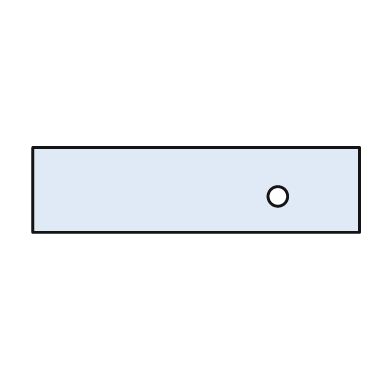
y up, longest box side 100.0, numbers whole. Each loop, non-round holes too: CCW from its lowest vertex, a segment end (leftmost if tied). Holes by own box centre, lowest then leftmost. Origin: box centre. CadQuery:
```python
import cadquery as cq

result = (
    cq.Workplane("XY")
    .moveTo(-50.0, -13.0)
    .lineTo(50.0, -13.0)
    .lineTo(50.0, 13.0)
    .lineTo(-50.0, 13.0)
    .close()
    .moveTo(25.0, -2.0)
    .circle(3.0)
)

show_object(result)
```